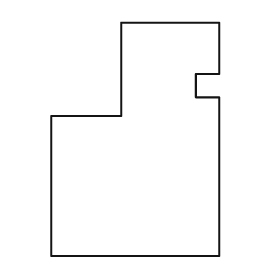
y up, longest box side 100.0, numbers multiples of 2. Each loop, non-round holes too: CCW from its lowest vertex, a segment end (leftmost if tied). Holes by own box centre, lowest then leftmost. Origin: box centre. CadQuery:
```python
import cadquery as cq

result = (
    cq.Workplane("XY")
    .moveTo(-36.0, -50.0)
    .lineTo(36.0, -50.0)
    .lineTo(36.0, 18.0)
    .lineTo(26.0, 18.0)
    .lineTo(26.0, 28.0)
    .lineTo(36.0, 28.0)
    .lineTo(36.0, 50.0)
    .lineTo(-6.0, 50.0)
    .lineTo(-6.0, 10.0)
    .lineTo(-36.0, 10.0)
    .close()
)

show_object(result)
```